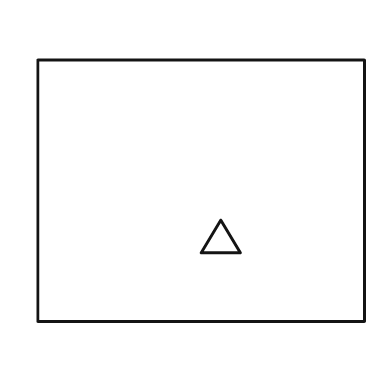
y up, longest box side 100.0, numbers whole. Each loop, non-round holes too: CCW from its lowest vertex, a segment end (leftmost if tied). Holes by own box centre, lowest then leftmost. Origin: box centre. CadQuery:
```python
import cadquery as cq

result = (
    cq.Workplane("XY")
    .moveTo(-50.0, -40.0)
    .lineTo(50.0, -40.0)
    .lineTo(50.0, 40.0)
    .lineTo(-50.0, 40.0)
    .close()
    .moveTo(0.0, -19.0)
    .lineTo(12.0, -19.0)
    .lineTo(6.0, -9.0)
    .close()
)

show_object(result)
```